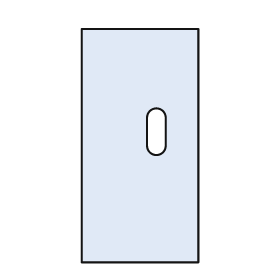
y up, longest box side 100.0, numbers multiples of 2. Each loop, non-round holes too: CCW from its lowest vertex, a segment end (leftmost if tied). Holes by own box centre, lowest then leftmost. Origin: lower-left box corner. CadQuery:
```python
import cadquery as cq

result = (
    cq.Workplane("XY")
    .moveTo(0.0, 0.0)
    .lineTo(50.0, 0.0)
    .lineTo(50.0, 100.0)
    .lineTo(0.0, 100.0)
    .close()
    .moveTo(28.0, 50.0)
    .threePointArc((32.0, 46.0), (36.0, 50.0))
    .lineTo(36.0, 62.0)
    .threePointArc((32.0, 66.0), (28.0, 62.0))
    .close()
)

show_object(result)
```